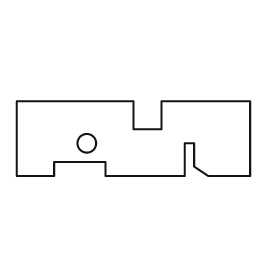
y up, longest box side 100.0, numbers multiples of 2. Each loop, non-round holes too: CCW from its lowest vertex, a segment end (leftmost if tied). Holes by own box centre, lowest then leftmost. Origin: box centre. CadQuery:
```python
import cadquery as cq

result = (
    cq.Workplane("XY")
    .moveTo(-50.0, -16.0)
    .lineTo(-34.0, -16.0)
    .lineTo(-34.0, -10.0)
    .lineTo(-12.0, -10.0)
    .lineTo(-12.0, -16.0)
    .lineTo(22.0, -16.0)
    .lineTo(22.0, -2.0)
    .lineTo(26.0, -2.0)
    .lineTo(26.0, -12.0)
    .lineTo(32.0, -16.0)
    .lineTo(50.0, -16.0)
    .lineTo(50.0, 16.0)
    .lineTo(12.0, 16.0)
    .lineTo(12.0, 4.0)
    .lineTo(0.0, 4.0)
    .lineTo(0.0, 16.0)
    .lineTo(-50.0, 16.0)
    .close()
    .moveTo(-20.0, -2.0)
    .circle(4.0)
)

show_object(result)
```